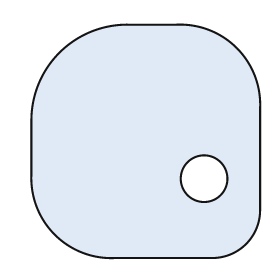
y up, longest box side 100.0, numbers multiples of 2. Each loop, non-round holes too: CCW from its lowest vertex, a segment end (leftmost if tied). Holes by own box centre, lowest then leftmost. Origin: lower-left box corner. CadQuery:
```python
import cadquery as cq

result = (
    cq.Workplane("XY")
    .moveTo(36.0, 0.0)
    .lineTo(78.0, 0.0)
    .threePointArc((92.0, 6.0), (98.0, 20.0))
    .lineTo(98.0, 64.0)
    .threePointArc((88.0, 90.0), (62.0, 100.0))
    .lineTo(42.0, 100.0)
    .threePointArc((12.0, 88.0), (0.0, 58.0))
    .lineTo(0.0, 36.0)
    .threePointArc((10.0, 10.0), (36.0, 0.0))
    .close()
    .moveTo(74.0, 34.0)
    .circle(10.0)
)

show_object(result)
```